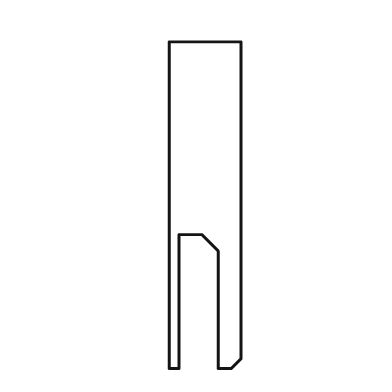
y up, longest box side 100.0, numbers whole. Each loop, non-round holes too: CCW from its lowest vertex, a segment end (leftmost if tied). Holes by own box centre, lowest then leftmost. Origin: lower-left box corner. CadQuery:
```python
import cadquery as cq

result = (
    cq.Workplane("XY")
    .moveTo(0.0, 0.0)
    .lineTo(3.0, 0.0)
    .lineTo(3.0, 41.0)
    .lineTo(10.0, 41.0)
    .lineTo(15.0, 36.0)
    .lineTo(15.0, 0.0)
    .lineTo(19.0, 0.0)
    .lineTo(22.0, 3.0)
    .lineTo(22.0, 100.0)
    .lineTo(0.0, 100.0)
    .close()
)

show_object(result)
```